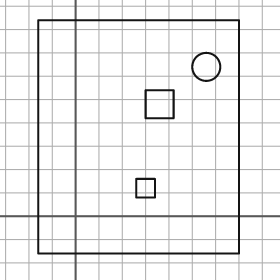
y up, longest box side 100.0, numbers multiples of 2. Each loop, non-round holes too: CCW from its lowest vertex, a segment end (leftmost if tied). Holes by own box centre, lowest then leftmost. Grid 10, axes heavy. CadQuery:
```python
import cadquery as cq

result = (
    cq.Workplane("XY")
    .moveTo(-16.0, -16.0)
    .lineTo(70.0, -16.0)
    .lineTo(70.0, 84.0)
    .lineTo(-16.0, 84.0)
    .close()
    .moveTo(26.0, 8.0)
    .lineTo(34.0, 8.0)
    .lineTo(34.0, 16.0)
    .lineTo(26.0, 16.0)
    .close()
    .moveTo(30.0, 42.0)
    .lineTo(42.0, 42.0)
    .lineTo(42.0, 54.0)
    .lineTo(30.0, 54.0)
    .close()
    .moveTo(56.0, 64.0)
    .circle(6.0)
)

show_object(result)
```